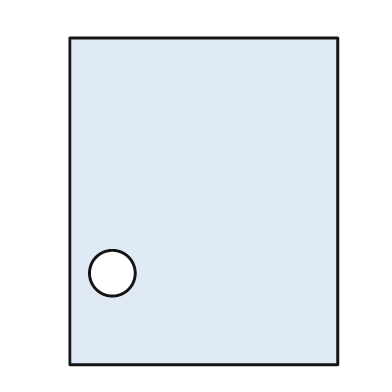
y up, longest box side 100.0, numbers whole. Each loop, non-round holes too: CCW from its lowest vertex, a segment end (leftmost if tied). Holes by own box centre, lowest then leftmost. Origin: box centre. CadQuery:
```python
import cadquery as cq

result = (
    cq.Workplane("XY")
    .moveTo(-41.0, -50.0)
    .lineTo(41.0, -50.0)
    .lineTo(41.0, 50.0)
    .lineTo(-41.0, 50.0)
    .close()
    .moveTo(-28.0, -22.0)
    .circle(7.0)
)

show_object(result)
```